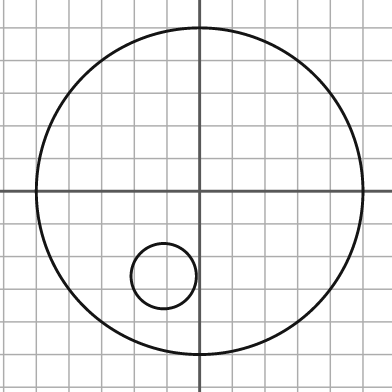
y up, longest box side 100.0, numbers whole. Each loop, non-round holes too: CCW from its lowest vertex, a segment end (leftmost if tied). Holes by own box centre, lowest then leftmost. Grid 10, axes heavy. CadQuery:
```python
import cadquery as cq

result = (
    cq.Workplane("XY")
    .moveTo(0.0, 0.0)
    .circle(50.0)
    .moveTo(-11.0, -26.0)
    .circle(10.0)
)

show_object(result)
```